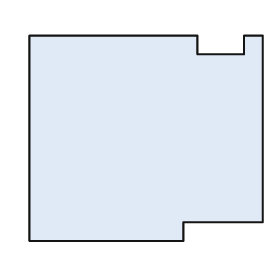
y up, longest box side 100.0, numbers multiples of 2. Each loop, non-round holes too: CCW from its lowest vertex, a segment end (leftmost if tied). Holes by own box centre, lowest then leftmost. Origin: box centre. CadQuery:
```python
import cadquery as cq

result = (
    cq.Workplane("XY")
    .moveTo(-50.0, -44.0)
    .lineTo(16.0, -44.0)
    .lineTo(16.0, -36.0)
    .lineTo(50.0, -36.0)
    .lineTo(50.0, 44.0)
    .lineTo(42.0, 44.0)
    .lineTo(42.0, 36.0)
    .lineTo(22.0, 36.0)
    .lineTo(22.0, 44.0)
    .lineTo(-50.0, 44.0)
    .close()
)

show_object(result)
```